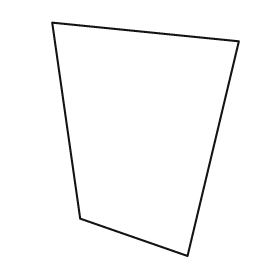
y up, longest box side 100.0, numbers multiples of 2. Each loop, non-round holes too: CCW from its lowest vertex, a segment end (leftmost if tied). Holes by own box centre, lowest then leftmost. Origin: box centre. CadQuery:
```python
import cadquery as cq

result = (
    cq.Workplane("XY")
    .moveTo(18.0, -50.0)
    .lineTo(40.0, 42.0)
    .lineTo(-40.0, 50.0)
    .lineTo(-28.0, -34.0)
    .close()
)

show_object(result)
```